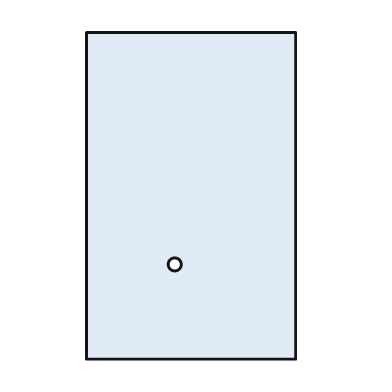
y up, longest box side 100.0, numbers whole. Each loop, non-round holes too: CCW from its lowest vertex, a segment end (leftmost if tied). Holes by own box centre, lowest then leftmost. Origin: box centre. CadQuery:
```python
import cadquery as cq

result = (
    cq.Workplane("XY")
    .moveTo(-32.0, -50.0)
    .lineTo(32.0, -50.0)
    .lineTo(32.0, 50.0)
    .lineTo(-32.0, 50.0)
    .close()
    .moveTo(-5.0, -21.0)
    .circle(2.0)
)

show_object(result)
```